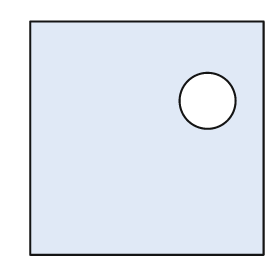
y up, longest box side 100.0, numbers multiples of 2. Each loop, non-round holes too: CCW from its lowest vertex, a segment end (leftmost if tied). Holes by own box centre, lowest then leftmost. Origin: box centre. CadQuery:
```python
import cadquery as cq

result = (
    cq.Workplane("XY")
    .moveTo(-50.0, -50.0)
    .lineTo(50.0, -50.0)
    .lineTo(50.0, 50.0)
    .lineTo(-50.0, 50.0)
    .close()
    .moveTo(26.0, 16.0)
    .circle(12.0)
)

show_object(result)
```